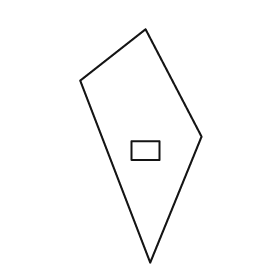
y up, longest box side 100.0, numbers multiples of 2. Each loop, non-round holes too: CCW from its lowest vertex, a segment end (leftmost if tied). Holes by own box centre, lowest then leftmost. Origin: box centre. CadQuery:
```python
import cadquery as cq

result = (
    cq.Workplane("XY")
    .moveTo(4.0, -50.0)
    .lineTo(26.0, 4.0)
    .lineTo(2.0, 50.0)
    .lineTo(-26.0, 28.0)
    .close()
    .moveTo(-4.0, -6.0)
    .lineTo(8.0, -6.0)
    .lineTo(8.0, 2.0)
    .lineTo(-4.0, 2.0)
    .close()
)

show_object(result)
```